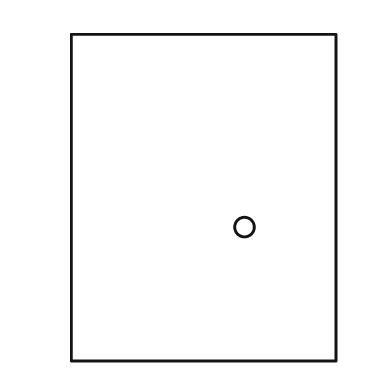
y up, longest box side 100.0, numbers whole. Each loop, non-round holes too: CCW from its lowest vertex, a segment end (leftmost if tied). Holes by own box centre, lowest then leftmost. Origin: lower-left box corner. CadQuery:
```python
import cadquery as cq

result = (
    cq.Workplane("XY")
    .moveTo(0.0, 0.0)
    .lineTo(81.0, 0.0)
    .lineTo(81.0, 100.0)
    .lineTo(0.0, 100.0)
    .close()
    .moveTo(53.0, 41.0)
    .circle(3.0)
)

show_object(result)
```